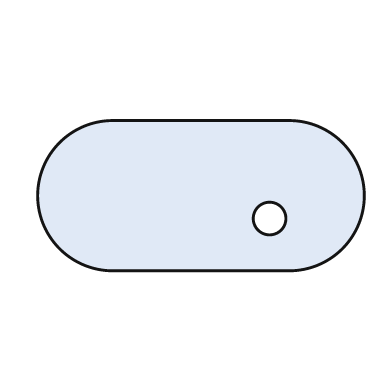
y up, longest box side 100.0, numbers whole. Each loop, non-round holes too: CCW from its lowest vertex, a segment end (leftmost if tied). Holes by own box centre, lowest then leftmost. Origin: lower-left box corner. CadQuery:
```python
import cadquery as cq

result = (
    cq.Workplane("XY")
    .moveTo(23.0, 0.0)
    .lineTo(77.0, 0.0)
    .threePointArc((100.0, 23.0), (77.0, 46.0))
    .lineTo(23.0, 46.0)
    .threePointArc((0.0, 23.0), (23.0, 0.0))
    .close()
    .moveTo(71.0, 16.0)
    .circle(5.0)
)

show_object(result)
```